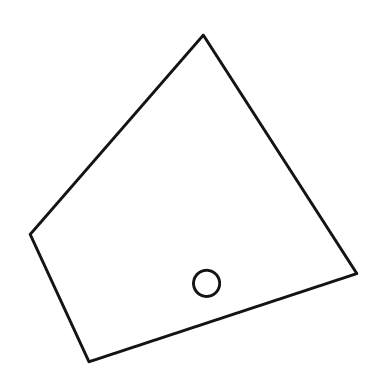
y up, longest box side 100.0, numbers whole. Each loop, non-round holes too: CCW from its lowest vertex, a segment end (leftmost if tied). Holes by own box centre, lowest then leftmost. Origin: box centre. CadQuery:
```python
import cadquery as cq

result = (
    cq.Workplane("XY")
    .moveTo(-32.0, -50.0)
    .lineTo(50.0, -23.0)
    .lineTo(3.0, 50.0)
    .lineTo(-50.0, -11.0)
    .close()
    .moveTo(4.0, -26.0)
    .circle(4.0)
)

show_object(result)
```